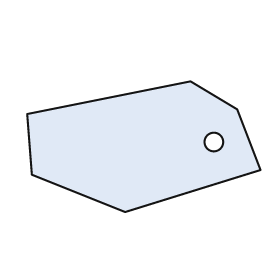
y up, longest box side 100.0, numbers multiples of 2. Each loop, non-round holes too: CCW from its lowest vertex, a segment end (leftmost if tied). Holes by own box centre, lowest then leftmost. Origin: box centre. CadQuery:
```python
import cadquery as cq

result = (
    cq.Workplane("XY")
    .moveTo(-8.0, -28.0)
    .lineTo(50.0, -10.0)
    .lineTo(40.0, 16.0)
    .lineTo(20.0, 28.0)
    .lineTo(-50.0, 14.0)
    .lineTo(-48.0, -12.0)
    .close()
    .moveTo(30.0, 2.0)
    .circle(4.0)
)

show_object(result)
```